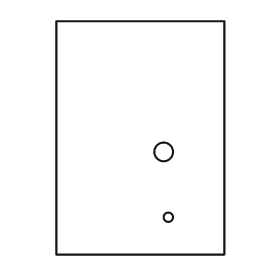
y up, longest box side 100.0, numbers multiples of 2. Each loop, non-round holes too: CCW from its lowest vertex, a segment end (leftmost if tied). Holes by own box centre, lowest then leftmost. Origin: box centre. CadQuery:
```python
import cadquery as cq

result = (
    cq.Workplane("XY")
    .moveTo(-36.0, -50.0)
    .lineTo(36.0, -50.0)
    .lineTo(36.0, 50.0)
    .lineTo(-36.0, 50.0)
    .close()
    .moveTo(12.0, -34.0)
    .circle(2.0)
    .moveTo(10.0, -6.0)
    .circle(4.0)
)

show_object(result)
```